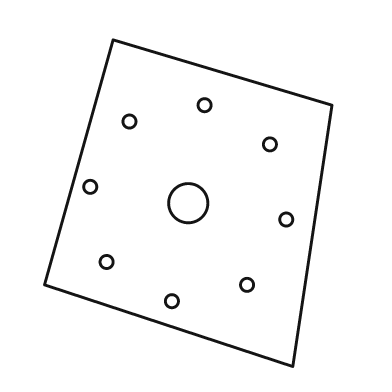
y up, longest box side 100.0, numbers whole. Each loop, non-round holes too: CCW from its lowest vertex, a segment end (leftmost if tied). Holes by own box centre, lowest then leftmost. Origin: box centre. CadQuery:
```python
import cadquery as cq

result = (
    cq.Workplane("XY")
    .moveTo(32.0, -50.0)
    .lineTo(44.0, 30.0)
    .lineTo(-23.0, 50.0)
    .lineTo(-44.0, -25.0)
    .close()
    .moveTo(-5.0, -30.0)
    .circle(2.0)
    .moveTo(18.0, -25.0)
    .circle(2.0)
    .moveTo(-25.0, -18.0)
    .circle(2.0)
    .moveTo(30.0, -5.0)
    .circle(2.0)
    .moveTo(0.0, 0.0)
    .circle(6.0)
    .moveTo(-30.0, 5.0)
    .circle(2.0)
    .moveTo(25.0, 18.0)
    .circle(2.0)
    .moveTo(-18.0, 25.0)
    .circle(2.0)
    .moveTo(5.0, 30.0)
    .circle(2.0)
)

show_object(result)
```